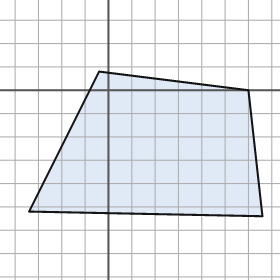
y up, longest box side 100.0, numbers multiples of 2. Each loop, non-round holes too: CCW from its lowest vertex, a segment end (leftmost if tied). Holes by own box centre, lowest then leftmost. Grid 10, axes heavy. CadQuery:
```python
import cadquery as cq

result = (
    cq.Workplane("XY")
    .moveTo(66.0, -54.0)
    .lineTo(60.0, 0.0)
    .lineTo(-4.0, 8.0)
    .lineTo(-34.0, -52.0)
    .close()
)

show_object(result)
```